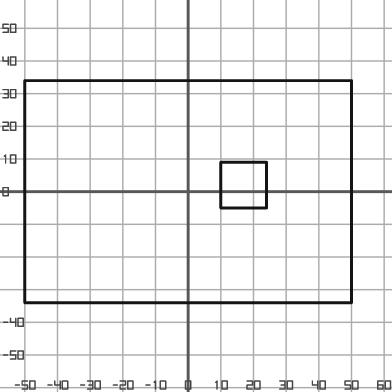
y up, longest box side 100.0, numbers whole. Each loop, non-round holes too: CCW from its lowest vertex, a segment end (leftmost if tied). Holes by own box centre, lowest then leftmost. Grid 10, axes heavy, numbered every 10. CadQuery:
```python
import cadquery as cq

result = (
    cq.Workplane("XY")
    .moveTo(-50.0, -34.0)
    .lineTo(50.0, -34.0)
    .lineTo(50.0, 34.0)
    .lineTo(-50.0, 34.0)
    .close()
    .moveTo(10.0, -5.0)
    .lineTo(24.0, -5.0)
    .lineTo(24.0, 9.0)
    .lineTo(10.0, 9.0)
    .close()
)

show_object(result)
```